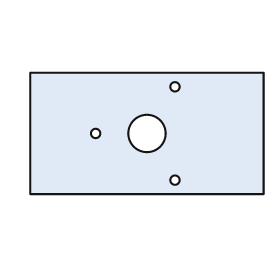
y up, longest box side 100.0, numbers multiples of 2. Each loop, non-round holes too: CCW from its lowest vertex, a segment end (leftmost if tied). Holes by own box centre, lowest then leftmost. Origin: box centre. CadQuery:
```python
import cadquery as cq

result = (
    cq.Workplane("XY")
    .moveTo(-50.0, -26.0)
    .lineTo(50.0, -26.0)
    .lineTo(50.0, 26.0)
    .lineTo(-50.0, 26.0)
    .close()
    .moveTo(12.0, -20.0)
    .circle(2.0)
    .moveTo(-22.0, 0.0)
    .circle(2.0)
    .moveTo(0.0, 0.0)
    .circle(8.0)
    .moveTo(12.0, 20.0)
    .circle(2.0)
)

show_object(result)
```